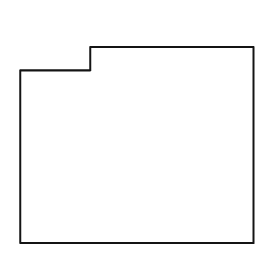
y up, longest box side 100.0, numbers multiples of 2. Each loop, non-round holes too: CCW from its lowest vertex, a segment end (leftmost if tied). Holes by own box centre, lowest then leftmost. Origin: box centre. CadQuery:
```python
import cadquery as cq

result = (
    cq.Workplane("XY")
    .moveTo(-50.0, -42.0)
    .lineTo(50.0, -42.0)
    .lineTo(50.0, 42.0)
    .lineTo(-20.0, 42.0)
    .lineTo(-20.0, 32.0)
    .lineTo(-50.0, 32.0)
    .close()
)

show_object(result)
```